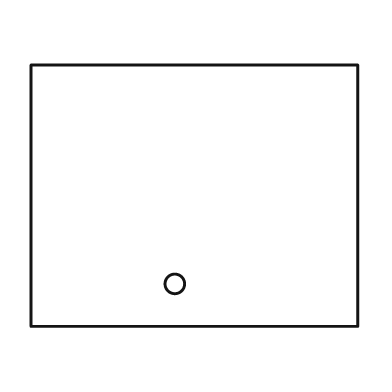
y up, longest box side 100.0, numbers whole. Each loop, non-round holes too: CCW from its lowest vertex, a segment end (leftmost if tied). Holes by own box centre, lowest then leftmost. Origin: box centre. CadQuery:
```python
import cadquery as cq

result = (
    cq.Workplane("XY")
    .moveTo(-50.0, -40.0)
    .lineTo(50.0, -40.0)
    .lineTo(50.0, 40.0)
    .lineTo(-50.0, 40.0)
    .close()
    .moveTo(-6.0, -27.0)
    .circle(3.0)
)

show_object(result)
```